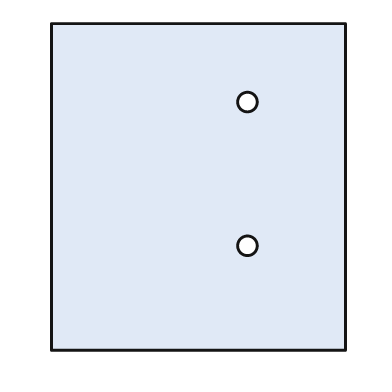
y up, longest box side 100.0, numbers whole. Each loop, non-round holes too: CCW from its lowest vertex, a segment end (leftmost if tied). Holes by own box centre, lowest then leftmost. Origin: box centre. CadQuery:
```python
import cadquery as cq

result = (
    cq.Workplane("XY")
    .moveTo(-45.0, -50.0)
    .lineTo(45.0, -50.0)
    .lineTo(45.0, 50.0)
    .lineTo(-45.0, 50.0)
    .close()
    .moveTo(15.0, -18.0)
    .circle(3.0)
    .moveTo(15.0, 26.0)
    .circle(3.0)
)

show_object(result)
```